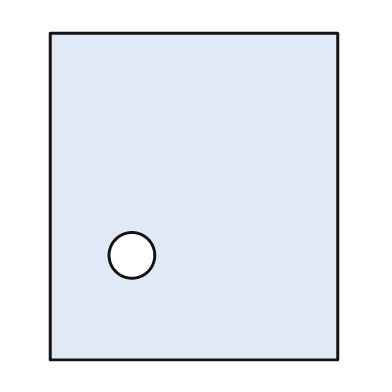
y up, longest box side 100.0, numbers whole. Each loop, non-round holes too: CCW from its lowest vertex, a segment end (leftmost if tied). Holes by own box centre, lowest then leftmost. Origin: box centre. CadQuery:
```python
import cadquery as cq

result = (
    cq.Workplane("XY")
    .moveTo(-44.0, -50.0)
    .lineTo(44.0, -50.0)
    .lineTo(44.0, 50.0)
    .lineTo(-44.0, 50.0)
    .close()
    .moveTo(-19.0, -18.0)
    .circle(7.0)
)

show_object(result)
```